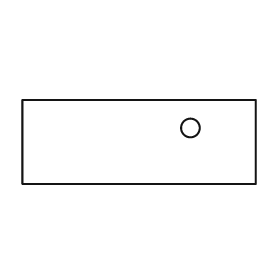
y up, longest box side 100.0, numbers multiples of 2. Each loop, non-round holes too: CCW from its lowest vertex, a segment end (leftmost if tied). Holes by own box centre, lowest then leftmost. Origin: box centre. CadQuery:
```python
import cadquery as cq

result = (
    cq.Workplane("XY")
    .moveTo(-50.0, -18.0)
    .lineTo(50.0, -18.0)
    .lineTo(50.0, 18.0)
    .lineTo(-50.0, 18.0)
    .close()
    .moveTo(22.0, 6.0)
    .circle(4.0)
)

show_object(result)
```